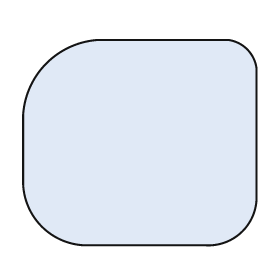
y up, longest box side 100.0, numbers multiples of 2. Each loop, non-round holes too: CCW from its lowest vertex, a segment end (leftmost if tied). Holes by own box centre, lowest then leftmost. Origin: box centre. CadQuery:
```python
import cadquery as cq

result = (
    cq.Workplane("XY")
    .moveTo(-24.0, -44.0)
    .lineTo(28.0, -44.0)
    .threePointArc((44.0, -38.0), (50.0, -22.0))
    .lineTo(50.0, 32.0)
    .threePointArc((46.0, 40.0), (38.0, 44.0))
    .lineTo(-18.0, 44.0)
    .threePointArc((-40.0, 34.0), (-50.0, 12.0))
    .lineTo(-50.0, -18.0)
    .threePointArc((-42.0, -36.0), (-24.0, -44.0))
    .close()
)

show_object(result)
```